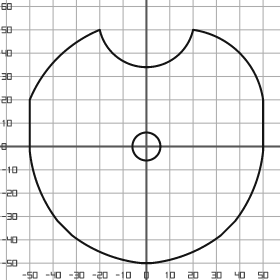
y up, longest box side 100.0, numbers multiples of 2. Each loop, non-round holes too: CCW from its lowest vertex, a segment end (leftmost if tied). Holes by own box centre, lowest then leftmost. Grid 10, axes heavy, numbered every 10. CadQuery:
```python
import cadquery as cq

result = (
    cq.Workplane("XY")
    .moveTo(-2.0, -50.0)
    .lineTo(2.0, -50.0)
    .threePointArc((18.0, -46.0), (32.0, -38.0))
    .lineTo(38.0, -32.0)
    .threePointArc((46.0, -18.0), (50.0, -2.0))
    .lineTo(50.0, 20.0)
    .threePointArc((40.0, 40.0), (20.0, 50.0))
    .threePointArc((0.0, 34.0), (-20.0, 50.0))
    .threePointArc((-38.0, 38.0), (-50.0, 20.0))
    .lineTo(-50.0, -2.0)
    .threePointArc((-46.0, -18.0), (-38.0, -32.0))
    .lineTo(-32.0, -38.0)
    .threePointArc((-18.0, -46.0), (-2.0, -50.0))
    .close()
    .moveTo(0.0, 0.0)
    .circle(6.0)
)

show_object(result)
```